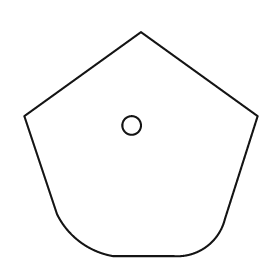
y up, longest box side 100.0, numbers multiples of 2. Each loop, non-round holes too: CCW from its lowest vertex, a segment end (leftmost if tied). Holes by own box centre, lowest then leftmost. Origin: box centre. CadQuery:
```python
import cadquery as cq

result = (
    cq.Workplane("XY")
    .moveTo(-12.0, -48.0)
    .lineTo(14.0, -48.0)
    .threePointArc((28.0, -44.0), (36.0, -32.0))
    .lineTo(50.0, 12.0)
    .lineTo(0.0, 48.0)
    .lineTo(-50.0, 12.0)
    .lineTo(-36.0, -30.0)
    .threePointArc((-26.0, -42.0), (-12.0, -48.0))
    .close()
    .moveTo(-4.0, 8.0)
    .circle(4.0)
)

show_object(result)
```